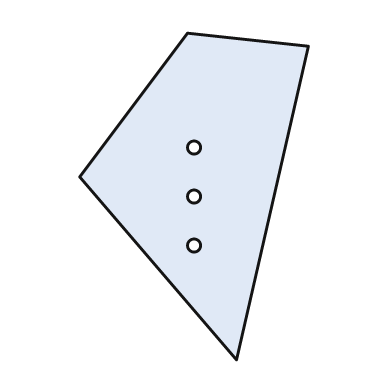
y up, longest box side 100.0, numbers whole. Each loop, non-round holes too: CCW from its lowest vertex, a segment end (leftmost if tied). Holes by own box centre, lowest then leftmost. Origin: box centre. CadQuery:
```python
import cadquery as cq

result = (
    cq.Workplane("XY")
    .moveTo(13.0, -50.0)
    .lineTo(35.0, 46.0)
    .lineTo(-2.0, 50.0)
    .lineTo(-35.0, 6.0)
    .close()
    .moveTo(0.0, -15.0)
    .circle(2.0)
    .moveTo(0.0, 0.0)
    .circle(2.0)
    .moveTo(0.0, 15.0)
    .circle(2.0)
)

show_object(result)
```